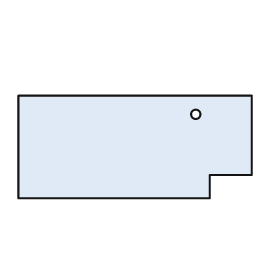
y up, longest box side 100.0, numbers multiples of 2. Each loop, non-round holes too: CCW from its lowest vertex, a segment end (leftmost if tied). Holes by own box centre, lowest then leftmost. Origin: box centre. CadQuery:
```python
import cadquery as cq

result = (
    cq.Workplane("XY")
    .moveTo(-50.0, -22.0)
    .lineTo(32.0, -22.0)
    .lineTo(32.0, -12.0)
    .lineTo(50.0, -12.0)
    .lineTo(50.0, 22.0)
    .lineTo(-50.0, 22.0)
    .close()
    .moveTo(26.0, 14.0)
    .circle(2.0)
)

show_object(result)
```